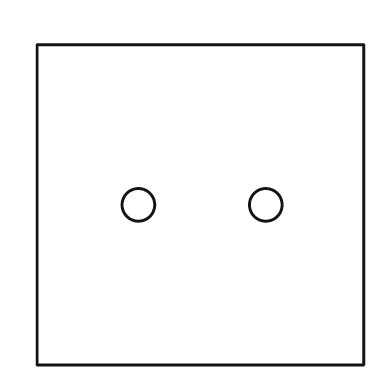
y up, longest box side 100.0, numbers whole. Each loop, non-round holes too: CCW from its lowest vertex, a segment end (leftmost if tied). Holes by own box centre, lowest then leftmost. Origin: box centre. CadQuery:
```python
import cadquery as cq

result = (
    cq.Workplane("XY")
    .moveTo(-50.0, -49.0)
    .lineTo(50.0, -49.0)
    .lineTo(50.0, 49.0)
    .lineTo(-50.0, 49.0)
    .close()
    .moveTo(-19.0, 0.0)
    .circle(5.0)
    .moveTo(20.0, 0.0)
    .circle(5.0)
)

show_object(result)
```